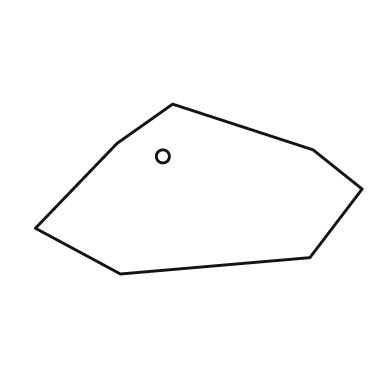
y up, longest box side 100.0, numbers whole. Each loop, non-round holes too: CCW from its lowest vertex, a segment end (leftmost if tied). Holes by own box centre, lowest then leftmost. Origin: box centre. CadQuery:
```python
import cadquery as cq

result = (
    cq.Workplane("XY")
    .moveTo(-24.0, -26.0)
    .lineTo(34.0, -21.0)
    .lineTo(50.0, 0.0)
    .lineTo(35.0, 12.0)
    .lineTo(-8.0, 26.0)
    .lineTo(-25.0, 14.0)
    .lineTo(-50.0, -12.0)
    .close()
    .moveTo(-11.0, 10.0)
    .circle(2.0)
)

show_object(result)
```